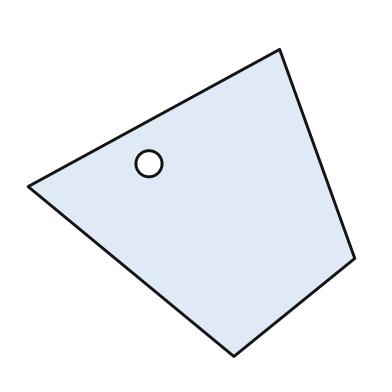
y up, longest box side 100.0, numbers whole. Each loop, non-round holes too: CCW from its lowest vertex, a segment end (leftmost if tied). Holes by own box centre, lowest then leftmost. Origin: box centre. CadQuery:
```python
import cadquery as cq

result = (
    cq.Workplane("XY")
    .moveTo(13.0, -47.0)
    .lineTo(50.0, -17.0)
    .lineTo(27.0, 47.0)
    .lineTo(-50.0, 5.0)
    .close()
    .moveTo(-13.0, 12.0)
    .circle(4.0)
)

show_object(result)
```